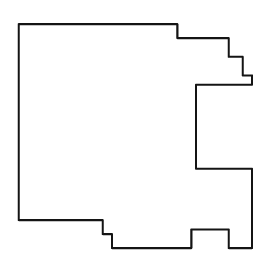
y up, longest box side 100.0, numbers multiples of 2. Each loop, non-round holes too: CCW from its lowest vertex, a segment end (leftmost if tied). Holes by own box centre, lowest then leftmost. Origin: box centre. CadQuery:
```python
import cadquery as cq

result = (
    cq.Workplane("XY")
    .moveTo(-10.0, -48.0)
    .lineTo(24.0, -48.0)
    .lineTo(24.0, -40.0)
    .lineTo(40.0, -40.0)
    .lineTo(40.0, -48.0)
    .lineTo(50.0, -48.0)
    .lineTo(50.0, -14.0)
    .lineTo(26.0, -14.0)
    .lineTo(26.0, 22.0)
    .lineTo(50.0, 22.0)
    .lineTo(50.0, 26.0)
    .lineTo(46.0, 26.0)
    .lineTo(46.0, 34.0)
    .lineTo(40.0, 34.0)
    .lineTo(40.0, 42.0)
    .lineTo(18.0, 42.0)
    .lineTo(18.0, 48.0)
    .lineTo(-50.0, 48.0)
    .lineTo(-50.0, -36.0)
    .lineTo(-14.0, -36.0)
    .lineTo(-14.0, -42.0)
    .lineTo(-10.0, -42.0)
    .close()
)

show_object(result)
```